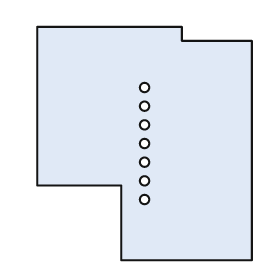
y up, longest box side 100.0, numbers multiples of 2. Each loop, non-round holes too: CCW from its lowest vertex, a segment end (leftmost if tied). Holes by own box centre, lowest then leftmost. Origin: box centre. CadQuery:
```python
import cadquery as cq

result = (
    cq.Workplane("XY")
    .moveTo(-10.0, -50.0)
    .lineTo(46.0, -50.0)
    .lineTo(46.0, 44.0)
    .lineTo(16.0, 44.0)
    .lineTo(16.0, 50.0)
    .lineTo(-46.0, 50.0)
    .lineTo(-46.0, -18.0)
    .lineTo(-10.0, -18.0)
    .close()
    .moveTo(0.0, -24.0)
    .circle(2.0)
    .moveTo(0.0, -16.0)
    .circle(2.0)
    .moveTo(0.0, -8.0)
    .circle(2.0)
    .moveTo(0.0, 0.0)
    .circle(2.0)
    .moveTo(0.0, 8.0)
    .circle(2.0)
    .moveTo(0.0, 16.0)
    .circle(2.0)
    .moveTo(0.0, 24.0)
    .circle(2.0)
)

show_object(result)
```